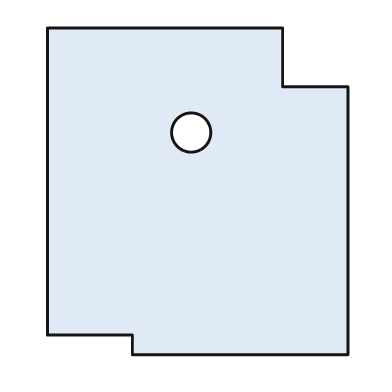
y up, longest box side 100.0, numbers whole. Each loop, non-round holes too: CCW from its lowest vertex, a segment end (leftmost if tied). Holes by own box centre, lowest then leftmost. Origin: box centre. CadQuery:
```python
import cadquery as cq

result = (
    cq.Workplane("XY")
    .moveTo(-20.0, -50.0)
    .lineTo(46.0, -50.0)
    .lineTo(46.0, 32.0)
    .lineTo(26.0, 32.0)
    .lineTo(26.0, 50.0)
    .lineTo(-46.0, 50.0)
    .lineTo(-46.0, -44.0)
    .lineTo(-20.0, -44.0)
    .close()
    .moveTo(-2.0, 18.0)
    .circle(6.0)
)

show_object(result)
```